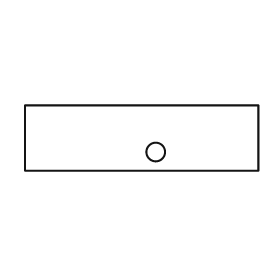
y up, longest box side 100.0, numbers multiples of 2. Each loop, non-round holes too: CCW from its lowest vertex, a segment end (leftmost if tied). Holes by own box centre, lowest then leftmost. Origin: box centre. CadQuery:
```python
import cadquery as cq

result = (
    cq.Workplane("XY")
    .moveTo(-50.0, -14.0)
    .lineTo(50.0, -14.0)
    .lineTo(50.0, 14.0)
    .lineTo(-50.0, 14.0)
    .close()
    .moveTo(6.0, -6.0)
    .circle(4.0)
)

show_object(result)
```